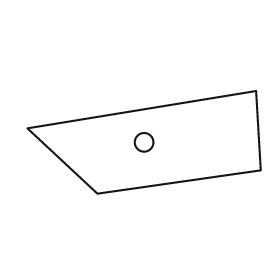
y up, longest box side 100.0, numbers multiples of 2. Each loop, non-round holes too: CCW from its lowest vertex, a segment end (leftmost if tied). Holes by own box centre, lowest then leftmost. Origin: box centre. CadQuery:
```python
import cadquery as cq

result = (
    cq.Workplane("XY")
    .moveTo(-20.0, -22.0)
    .lineTo(50.0, -12.0)
    .lineTo(48.0, 22.0)
    .lineTo(-50.0, 6.0)
    .close()
    .moveTo(0.0, 0.0)
    .circle(4.0)
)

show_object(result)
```